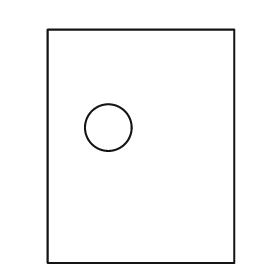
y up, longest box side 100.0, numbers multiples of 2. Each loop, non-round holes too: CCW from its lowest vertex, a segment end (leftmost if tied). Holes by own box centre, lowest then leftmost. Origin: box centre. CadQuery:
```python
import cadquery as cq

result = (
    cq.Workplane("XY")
    .moveTo(-40.0, -50.0)
    .lineTo(40.0, -50.0)
    .lineTo(40.0, 50.0)
    .lineTo(-40.0, 50.0)
    .close()
    .moveTo(-14.0, 8.0)
    .circle(10.0)
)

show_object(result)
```